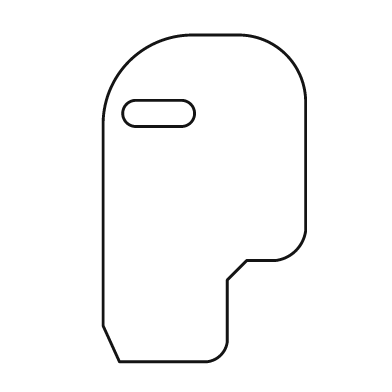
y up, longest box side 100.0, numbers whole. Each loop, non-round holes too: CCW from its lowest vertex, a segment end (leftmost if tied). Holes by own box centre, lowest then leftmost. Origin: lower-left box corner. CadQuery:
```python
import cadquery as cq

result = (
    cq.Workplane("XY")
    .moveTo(5.0, 0.0)
    .lineTo(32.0, 0.0)
    .threePointArc((36.0, 2.0), (38.0, 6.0))
    .lineTo(38.0, 25.0)
    .lineTo(44.0, 31.0)
    .lineTo(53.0, 31.0)
    .threePointArc((59.0, 34.0), (62.0, 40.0))
    .lineTo(62.0, 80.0)
    .threePointArc((56.0, 94.0), (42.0, 100.0))
    .lineTo(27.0, 100.0)
    .threePointArc((8.0, 92.0), (0.0, 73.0))
    .lineTo(0.0, 11.0)
    .close()
    .moveTo(10.0, 72.0)
    .lineTo(24.0, 72.0)
    .threePointArc((28.0, 76.0), (24.0, 80.0))
    .lineTo(10.0, 80.0)
    .threePointArc((6.0, 76.0), (10.0, 72.0))
    .close()
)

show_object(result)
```